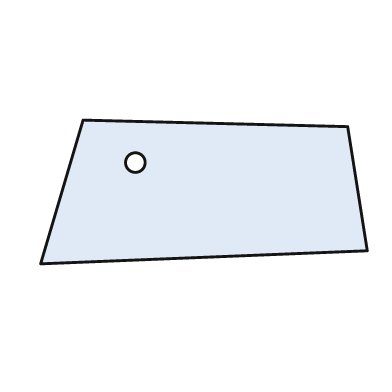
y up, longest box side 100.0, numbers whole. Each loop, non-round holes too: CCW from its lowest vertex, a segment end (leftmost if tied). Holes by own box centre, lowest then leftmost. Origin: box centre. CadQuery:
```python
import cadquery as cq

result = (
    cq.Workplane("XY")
    .moveTo(-50.0, -22.0)
    .lineTo(50.0, -18.0)
    .lineTo(44.0, 20.0)
    .lineTo(-37.0, 22.0)
    .close()
    .moveTo(-21.0, 9.0)
    .circle(3.0)
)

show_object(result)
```